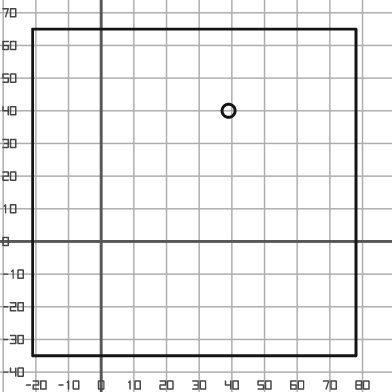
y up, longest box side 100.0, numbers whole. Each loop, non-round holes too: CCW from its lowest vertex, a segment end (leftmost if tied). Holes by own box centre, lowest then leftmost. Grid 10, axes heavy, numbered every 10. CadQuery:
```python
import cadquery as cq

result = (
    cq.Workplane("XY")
    .moveTo(-21.0, -35.0)
    .lineTo(78.0, -35.0)
    .lineTo(78.0, 65.0)
    .lineTo(-21.0, 65.0)
    .close()
    .moveTo(39.0, 40.0)
    .circle(2.0)
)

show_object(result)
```